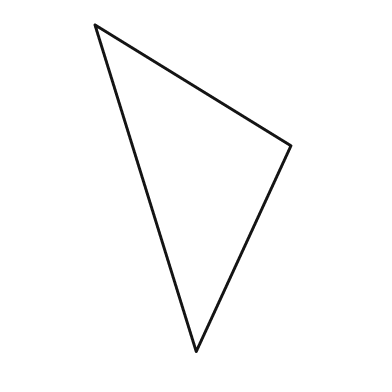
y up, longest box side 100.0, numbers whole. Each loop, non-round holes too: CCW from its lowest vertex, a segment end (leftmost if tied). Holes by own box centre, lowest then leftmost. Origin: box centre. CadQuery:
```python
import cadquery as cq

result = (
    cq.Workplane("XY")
    .moveTo(1.0, -50.0)
    .lineTo(30.0, 13.0)
    .lineTo(-30.0, 50.0)
    .close()
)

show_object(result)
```